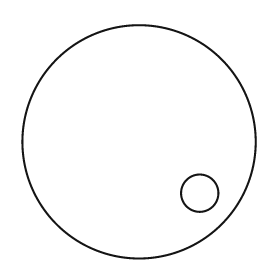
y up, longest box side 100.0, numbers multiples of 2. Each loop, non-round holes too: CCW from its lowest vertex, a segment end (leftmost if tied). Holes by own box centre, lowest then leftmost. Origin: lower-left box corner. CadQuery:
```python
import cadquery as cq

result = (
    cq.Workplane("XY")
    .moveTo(50.0, 50.0)
    .circle(50.0)
    .moveTo(76.0, 28.0)
    .circle(8.0)
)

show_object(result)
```